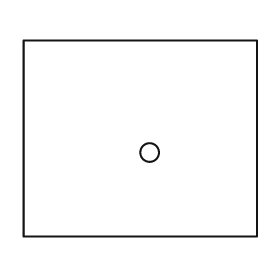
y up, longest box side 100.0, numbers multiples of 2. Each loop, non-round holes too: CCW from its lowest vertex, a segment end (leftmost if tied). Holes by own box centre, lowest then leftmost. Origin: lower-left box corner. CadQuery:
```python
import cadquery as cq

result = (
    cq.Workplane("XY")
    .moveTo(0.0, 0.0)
    .lineTo(100.0, 0.0)
    .lineTo(100.0, 84.0)
    .lineTo(0.0, 84.0)
    .close()
    .moveTo(54.0, 36.0)
    .circle(4.0)
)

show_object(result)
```